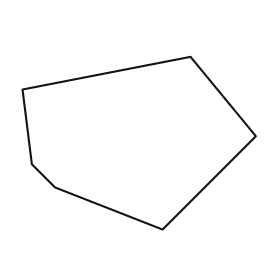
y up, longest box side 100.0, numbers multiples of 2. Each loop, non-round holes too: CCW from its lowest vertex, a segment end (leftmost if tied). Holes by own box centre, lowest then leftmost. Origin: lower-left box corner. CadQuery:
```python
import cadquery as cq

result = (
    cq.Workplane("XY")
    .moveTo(60.0, 0.0)
    .lineTo(100.0, 40.0)
    .lineTo(72.0, 74.0)
    .lineTo(0.0, 60.0)
    .lineTo(4.0, 28.0)
    .lineTo(14.0, 18.0)
    .close()
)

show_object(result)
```